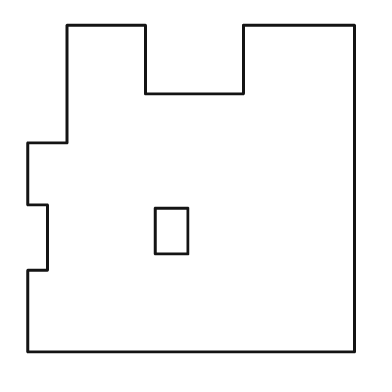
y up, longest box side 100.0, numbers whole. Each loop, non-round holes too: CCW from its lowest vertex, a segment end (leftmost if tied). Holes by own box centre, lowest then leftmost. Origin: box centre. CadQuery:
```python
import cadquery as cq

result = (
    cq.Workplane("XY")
    .moveTo(-50.0, -50.0)
    .lineTo(50.0, -50.0)
    .lineTo(50.0, 50.0)
    .lineTo(16.0, 50.0)
    .lineTo(16.0, 29.0)
    .lineTo(-14.0, 29.0)
    .lineTo(-14.0, 50.0)
    .lineTo(-38.0, 50.0)
    .lineTo(-38.0, 14.0)
    .lineTo(-50.0, 14.0)
    .lineTo(-50.0, -5.0)
    .lineTo(-44.0, -5.0)
    .lineTo(-44.0, -25.0)
    .lineTo(-50.0, -25.0)
    .close()
    .moveTo(-11.0, -20.0)
    .lineTo(-1.0, -20.0)
    .lineTo(-1.0, -6.0)
    .lineTo(-11.0, -6.0)
    .close()
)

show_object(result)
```